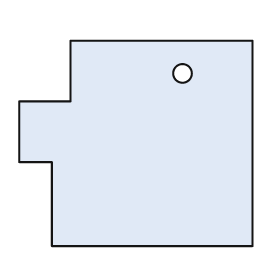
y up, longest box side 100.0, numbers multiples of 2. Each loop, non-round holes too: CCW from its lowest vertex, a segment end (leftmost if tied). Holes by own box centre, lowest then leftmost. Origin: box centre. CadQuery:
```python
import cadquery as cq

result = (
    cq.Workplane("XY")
    .moveTo(-36.0, -44.0)
    .lineTo(50.0, -44.0)
    .lineTo(50.0, 44.0)
    .lineTo(-28.0, 44.0)
    .lineTo(-28.0, 18.0)
    .lineTo(-50.0, 18.0)
    .lineTo(-50.0, -8.0)
    .lineTo(-36.0, -8.0)
    .close()
    .moveTo(20.0, 30.0)
    .circle(4.0)
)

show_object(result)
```